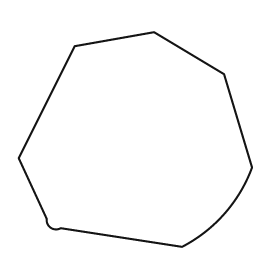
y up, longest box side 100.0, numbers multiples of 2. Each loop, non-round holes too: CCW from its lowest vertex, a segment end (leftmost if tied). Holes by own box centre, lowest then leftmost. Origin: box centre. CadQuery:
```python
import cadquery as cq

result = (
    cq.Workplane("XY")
    .moveTo(20.0, -46.0)
    .threePointArc((38.0, -32.0), (50.0, -12.0))
    .lineTo(38.0, 28.0)
    .lineTo(8.0, 46.0)
    .lineTo(-26.0, 40.0)
    .lineTo(-50.0, -8.0)
    .lineTo(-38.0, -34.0)
    .threePointArc((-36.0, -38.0), (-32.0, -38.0))
    .close()
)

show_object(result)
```